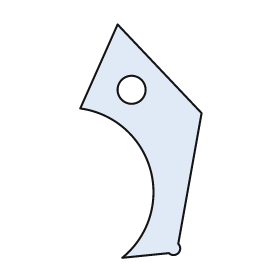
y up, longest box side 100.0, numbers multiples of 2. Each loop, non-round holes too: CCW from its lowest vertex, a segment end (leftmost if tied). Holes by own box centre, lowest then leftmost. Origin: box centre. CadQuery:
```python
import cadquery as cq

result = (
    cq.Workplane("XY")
    .moveTo(-8.0, -50.0)
    .lineTo(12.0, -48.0)
    .threePointArc((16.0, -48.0), (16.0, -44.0))
    .lineTo(26.0, 12.0)
    .lineTo(-10.0, 50.0)
    .lineTo(-26.0, 14.0)
    .threePointArc((4.0, -12.0), (-8.0, -50.0))
    .close()
    .moveTo(-4.0, 22.0)
    .circle(6.0)
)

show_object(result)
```